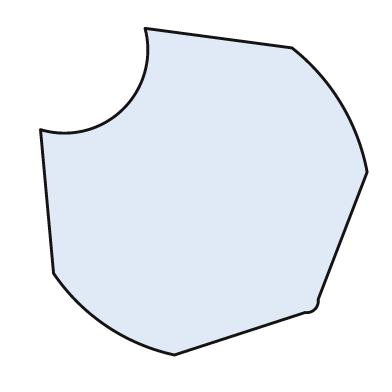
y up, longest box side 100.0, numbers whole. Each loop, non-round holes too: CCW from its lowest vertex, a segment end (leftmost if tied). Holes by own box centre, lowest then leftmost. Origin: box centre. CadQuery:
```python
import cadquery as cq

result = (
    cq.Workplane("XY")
    .moveTo(-9.0, -50.0)
    .lineTo(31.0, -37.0)
    .threePointArc((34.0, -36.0), (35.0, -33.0))
    .lineTo(50.0, 6.0)
    .threePointArc((42.0, 27.0), (27.0, 44.0))
    .lineTo(-18.0, 50.0)
    .threePointArc((-25.0, 25.0), (-50.0, 19.0))
    .lineTo(-46.0, -25.0)
    .threePointArc((-30.0, -41.0), (-9.0, -50.0))
    .close()
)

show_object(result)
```